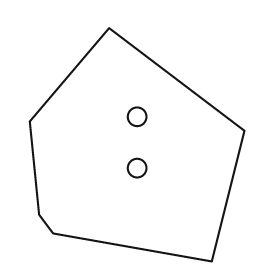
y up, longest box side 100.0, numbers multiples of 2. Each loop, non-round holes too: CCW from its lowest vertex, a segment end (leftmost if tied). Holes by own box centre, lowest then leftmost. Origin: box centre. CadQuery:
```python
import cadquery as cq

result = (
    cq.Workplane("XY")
    .moveTo(32.0, -50.0)
    .lineTo(46.0, 6.0)
    .lineTo(-12.0, 50.0)
    .lineTo(-46.0, 10.0)
    .lineTo(-42.0, -30.0)
    .lineTo(-36.0, -38.0)
    .close()
    .moveTo(0.0, -10.0)
    .circle(4.0)
    .moveTo(0.0, 12.0)
    .circle(4.0)
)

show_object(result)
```